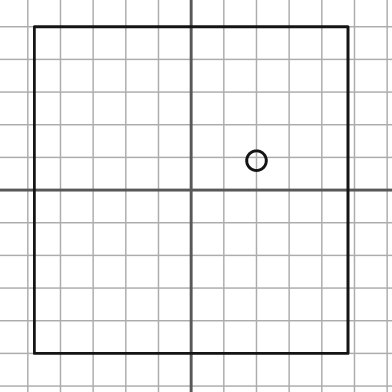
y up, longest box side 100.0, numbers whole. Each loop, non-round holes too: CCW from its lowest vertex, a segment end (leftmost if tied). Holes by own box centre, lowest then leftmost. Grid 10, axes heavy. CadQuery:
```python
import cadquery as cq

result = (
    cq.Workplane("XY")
    .moveTo(-48.0, -50.0)
    .lineTo(48.0, -50.0)
    .lineTo(48.0, 50.0)
    .lineTo(-48.0, 50.0)
    .close()
    .moveTo(20.0, 9.0)
    .circle(3.0)
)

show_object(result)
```